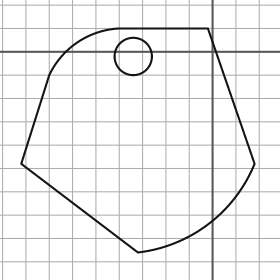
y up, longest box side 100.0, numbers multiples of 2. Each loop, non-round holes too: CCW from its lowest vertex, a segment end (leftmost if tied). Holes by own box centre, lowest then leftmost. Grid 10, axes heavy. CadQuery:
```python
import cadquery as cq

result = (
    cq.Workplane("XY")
    .moveTo(-32.0, -86.0)
    .threePointArc((-2.0, -74.0), (18.0, -48.0))
    .lineTo(-2.0, 10.0)
    .lineTo(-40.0, 10.0)
    .threePointArc((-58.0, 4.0), (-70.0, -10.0))
    .lineTo(-82.0, -48.0)
    .close()
    .moveTo(-34.0, -2.0)
    .circle(8.0)
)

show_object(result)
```